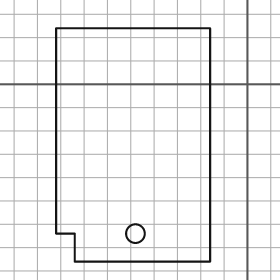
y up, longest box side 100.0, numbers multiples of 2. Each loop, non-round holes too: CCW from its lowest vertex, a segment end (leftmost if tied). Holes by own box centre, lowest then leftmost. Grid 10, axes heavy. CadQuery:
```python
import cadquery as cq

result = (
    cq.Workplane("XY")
    .moveTo(-74.0, -76.0)
    .lineTo(-16.0, -76.0)
    .lineTo(-16.0, 24.0)
    .lineTo(-82.0, 24.0)
    .lineTo(-82.0, -64.0)
    .lineTo(-74.0, -64.0)
    .close()
    .moveTo(-48.0, -64.0)
    .circle(4.0)
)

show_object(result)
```